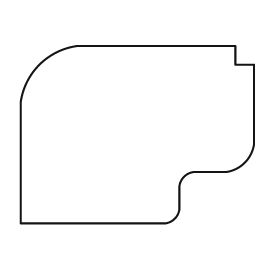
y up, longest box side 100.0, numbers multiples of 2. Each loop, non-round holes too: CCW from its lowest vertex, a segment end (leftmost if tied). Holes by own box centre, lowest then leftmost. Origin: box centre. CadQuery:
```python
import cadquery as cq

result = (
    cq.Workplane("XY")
    .moveTo(-50.0, -38.0)
    .lineTo(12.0, -38.0)
    .threePointArc((16.0, -36.0), (18.0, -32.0))
    .lineTo(18.0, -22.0)
    .threePointArc((20.0, -18.0), (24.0, -16.0))
    .lineTo(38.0, -16.0)
    .threePointArc((46.0, -12.0), (50.0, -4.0))
    .lineTo(50.0, 30.0)
    .lineTo(42.0, 30.0)
    .lineTo(42.0, 38.0)
    .lineTo(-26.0, 38.0)
    .threePointArc((-42.0, 30.0), (-50.0, 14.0))
    .close()
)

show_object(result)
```